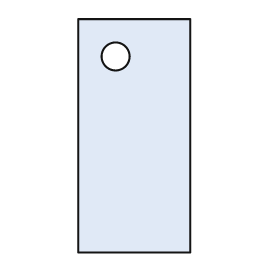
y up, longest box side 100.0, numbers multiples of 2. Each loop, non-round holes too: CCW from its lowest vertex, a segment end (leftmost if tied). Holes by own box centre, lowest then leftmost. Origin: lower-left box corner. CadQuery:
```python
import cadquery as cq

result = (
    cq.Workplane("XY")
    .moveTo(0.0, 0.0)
    .lineTo(48.0, 0.0)
    .lineTo(48.0, 100.0)
    .lineTo(0.0, 100.0)
    .close()
    .moveTo(16.0, 84.0)
    .circle(6.0)
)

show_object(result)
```